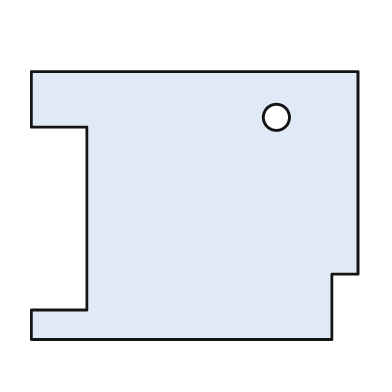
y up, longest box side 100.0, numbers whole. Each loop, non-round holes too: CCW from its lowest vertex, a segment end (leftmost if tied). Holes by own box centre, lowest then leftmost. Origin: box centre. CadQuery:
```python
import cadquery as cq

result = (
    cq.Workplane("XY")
    .moveTo(-50.0, -41.0)
    .lineTo(42.0, -41.0)
    .lineTo(42.0, -21.0)
    .lineTo(50.0, -21.0)
    .lineTo(50.0, 41.0)
    .lineTo(-50.0, 41.0)
    .lineTo(-50.0, 24.0)
    .lineTo(-33.0, 24.0)
    .lineTo(-33.0, -32.0)
    .lineTo(-50.0, -32.0)
    .close()
    .moveTo(25.0, 27.0)
    .circle(4.0)
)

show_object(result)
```